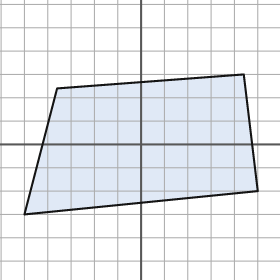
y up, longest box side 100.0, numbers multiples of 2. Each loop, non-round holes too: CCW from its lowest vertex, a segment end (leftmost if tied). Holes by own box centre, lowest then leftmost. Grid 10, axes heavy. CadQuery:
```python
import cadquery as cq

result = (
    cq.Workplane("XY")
    .moveTo(-50.0, -30.0)
    .lineTo(50.0, -20.0)
    .lineTo(44.0, 30.0)
    .lineTo(-36.0, 24.0)
    .close()
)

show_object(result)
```